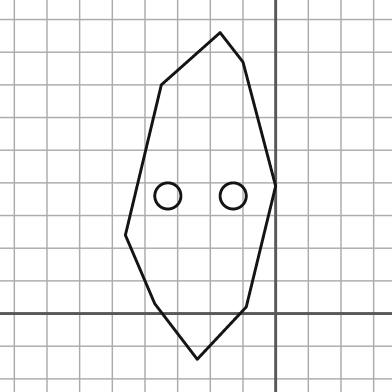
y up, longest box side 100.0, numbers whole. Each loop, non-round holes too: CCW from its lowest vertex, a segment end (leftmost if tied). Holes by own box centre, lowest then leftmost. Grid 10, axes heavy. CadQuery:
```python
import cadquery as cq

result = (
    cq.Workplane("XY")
    .moveTo(-24.0, -14.0)
    .lineTo(-9.0, 2.0)
    .lineTo(0.0, 39.0)
    .lineTo(-10.0, 77.0)
    .lineTo(-17.0, 86.0)
    .lineTo(-35.0, 70.0)
    .lineTo(-46.0, 24.0)
    .lineTo(-37.0, 3.0)
    .close()
    .moveTo(-33.0, 36.0)
    .circle(4.0)
    .moveTo(-13.0, 36.0)
    .circle(4.0)
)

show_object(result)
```